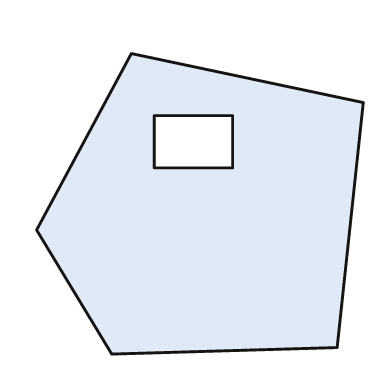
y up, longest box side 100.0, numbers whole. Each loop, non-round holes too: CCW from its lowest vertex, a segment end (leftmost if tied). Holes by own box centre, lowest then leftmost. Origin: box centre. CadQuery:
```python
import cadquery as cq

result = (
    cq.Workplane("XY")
    .moveTo(-27.0, -46.0)
    .lineTo(42.0, -44.0)
    .lineTo(50.0, 31.0)
    .lineTo(-21.0, 46.0)
    .lineTo(-50.0, -8.0)
    .close()
    .moveTo(-14.0, 11.0)
    .lineTo(10.0, 11.0)
    .lineTo(10.0, 27.0)
    .lineTo(-14.0, 27.0)
    .close()
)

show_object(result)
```